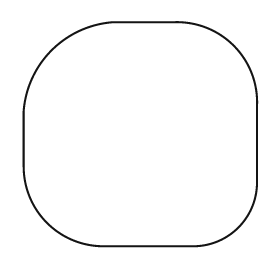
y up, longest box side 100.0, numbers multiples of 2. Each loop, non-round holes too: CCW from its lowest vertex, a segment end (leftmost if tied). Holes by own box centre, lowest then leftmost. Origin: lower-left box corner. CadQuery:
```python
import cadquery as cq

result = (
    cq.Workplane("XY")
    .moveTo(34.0, 0.0)
    .lineTo(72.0, 0.0)
    .threePointArc((92.0, 8.0), (100.0, 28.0))
    .lineTo(100.0, 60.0)
    .threePointArc((90.0, 86.0), (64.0, 96.0))
    .lineTo(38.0, 96.0)
    .threePointArc((12.0, 84.0), (0.0, 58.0))
    .lineTo(0.0, 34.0)
    .threePointArc((10.0, 10.0), (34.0, 0.0))
    .close()
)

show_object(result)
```